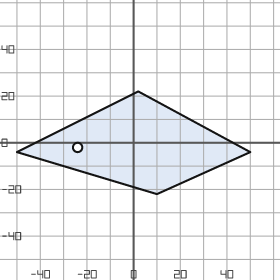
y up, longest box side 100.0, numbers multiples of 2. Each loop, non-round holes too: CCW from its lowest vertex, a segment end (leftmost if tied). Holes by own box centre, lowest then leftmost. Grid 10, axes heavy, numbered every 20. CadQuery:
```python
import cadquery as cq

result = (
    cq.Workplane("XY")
    .moveTo(10.0, -22.0)
    .lineTo(50.0, -4.0)
    .lineTo(2.0, 22.0)
    .lineTo(-50.0, -4.0)
    .close()
    .moveTo(-24.0, -2.0)
    .circle(2.0)
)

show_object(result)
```